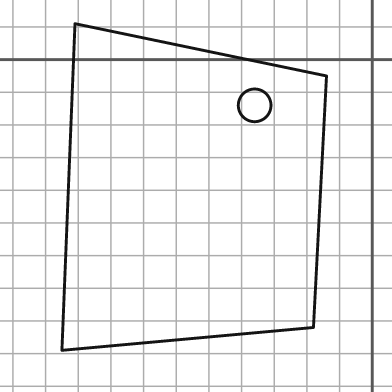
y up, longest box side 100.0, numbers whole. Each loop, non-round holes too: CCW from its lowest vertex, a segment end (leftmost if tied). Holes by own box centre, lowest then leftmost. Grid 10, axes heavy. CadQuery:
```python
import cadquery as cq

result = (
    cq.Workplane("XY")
    .moveTo(-95.0, -89.0)
    .lineTo(-18.0, -82.0)
    .lineTo(-14.0, -5.0)
    .lineTo(-91.0, 11.0)
    .close()
    .moveTo(-36.0, -14.0)
    .circle(5.0)
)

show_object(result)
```